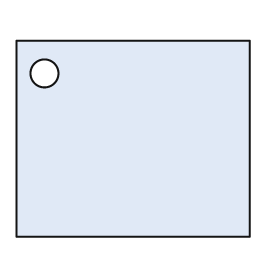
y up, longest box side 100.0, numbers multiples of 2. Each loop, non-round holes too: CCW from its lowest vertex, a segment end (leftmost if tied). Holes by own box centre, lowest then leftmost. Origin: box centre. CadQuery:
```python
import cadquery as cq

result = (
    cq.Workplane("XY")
    .moveTo(-50.0, -42.0)
    .lineTo(50.0, -42.0)
    .lineTo(50.0, 42.0)
    .lineTo(-50.0, 42.0)
    .close()
    .moveTo(-38.0, 28.0)
    .circle(6.0)
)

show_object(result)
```